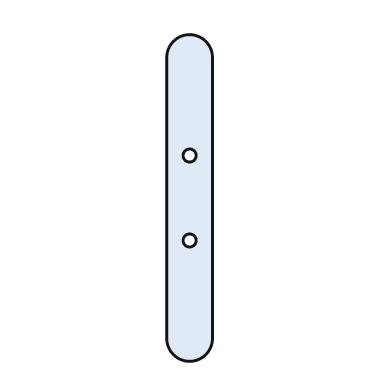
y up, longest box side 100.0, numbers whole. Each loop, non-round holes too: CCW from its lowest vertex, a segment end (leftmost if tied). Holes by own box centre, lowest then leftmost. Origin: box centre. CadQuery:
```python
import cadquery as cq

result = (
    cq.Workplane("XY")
    .moveTo(-7.0, -43.0)
    .threePointArc((0.0, -50.0), (7.0, -43.0))
    .lineTo(7.0, 43.0)
    .threePointArc((0.0, 50.0), (-7.0, 43.0))
    .close()
    .moveTo(0.0, -13.0)
    .circle(2.0)
    .moveTo(0.0, 13.0)
    .circle(2.0)
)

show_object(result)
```